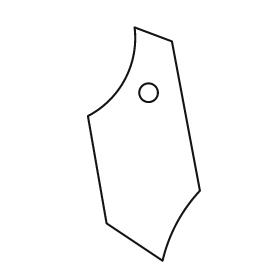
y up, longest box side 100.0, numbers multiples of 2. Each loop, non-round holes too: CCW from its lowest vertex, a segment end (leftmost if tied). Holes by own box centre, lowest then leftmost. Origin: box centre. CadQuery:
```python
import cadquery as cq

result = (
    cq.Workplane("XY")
    .moveTo(8.0, -50.0)
    .threePointArc((14.0, -34.0), (24.0, -20.0))
    .lineTo(12.0, 44.0)
    .lineTo(-4.0, 50.0)
    .threePointArc((-8.0, 28.0), (-24.0, 12.0))
    .lineTo(-16.0, -34.0)
    .close()
    .moveTo(2.0, 22.0)
    .circle(4.0)
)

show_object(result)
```